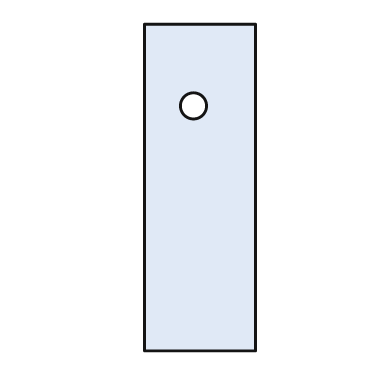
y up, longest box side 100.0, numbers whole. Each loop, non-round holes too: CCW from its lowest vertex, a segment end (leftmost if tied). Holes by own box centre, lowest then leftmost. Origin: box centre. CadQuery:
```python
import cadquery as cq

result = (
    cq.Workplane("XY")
    .moveTo(-17.0, -50.0)
    .lineTo(17.0, -50.0)
    .lineTo(17.0, 50.0)
    .lineTo(-17.0, 50.0)
    .close()
    .moveTo(-2.0, 25.0)
    .circle(4.0)
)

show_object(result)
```